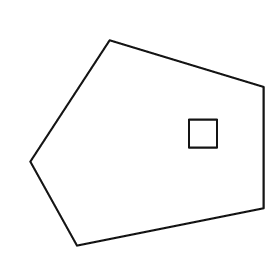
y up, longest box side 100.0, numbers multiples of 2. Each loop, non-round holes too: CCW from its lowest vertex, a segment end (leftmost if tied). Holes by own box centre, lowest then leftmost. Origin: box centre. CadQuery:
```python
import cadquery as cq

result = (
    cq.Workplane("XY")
    .moveTo(-30.0, -44.0)
    .lineTo(50.0, -28.0)
    .lineTo(50.0, 24.0)
    .lineTo(-16.0, 44.0)
    .lineTo(-50.0, -8.0)
    .close()
    .moveTo(18.0, -2.0)
    .lineTo(30.0, -2.0)
    .lineTo(30.0, 10.0)
    .lineTo(18.0, 10.0)
    .close()
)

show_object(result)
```